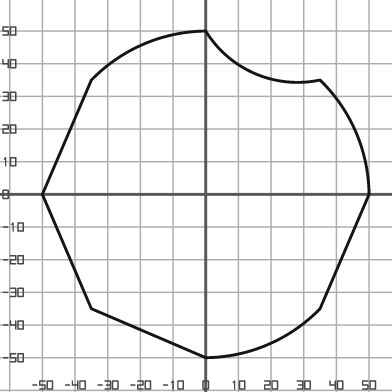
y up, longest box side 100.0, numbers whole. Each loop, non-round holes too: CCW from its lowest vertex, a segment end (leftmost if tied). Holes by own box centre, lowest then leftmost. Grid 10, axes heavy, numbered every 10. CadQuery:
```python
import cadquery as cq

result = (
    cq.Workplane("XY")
    .moveTo(0.0, -50.0)
    .threePointArc((19.0, -46.0), (35.0, -35.0))
    .lineTo(50.0, 0.0)
    .threePointArc((46.0, 19.0), (35.0, 35.0))
    .threePointArc((15.0, 37.0), (0.0, 50.0))
    .threePointArc((-19.0, 46.0), (-35.0, 35.0))
    .lineTo(-50.0, 0.0)
    .lineTo(-35.0, -35.0)
    .close()
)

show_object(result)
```